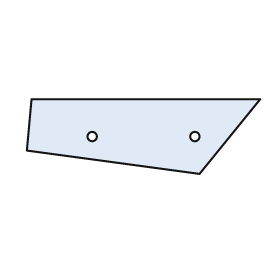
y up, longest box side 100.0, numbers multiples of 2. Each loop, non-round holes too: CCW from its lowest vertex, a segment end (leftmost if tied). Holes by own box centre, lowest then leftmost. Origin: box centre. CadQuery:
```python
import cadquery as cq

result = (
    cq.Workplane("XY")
    .moveTo(24.0, -16.0)
    .lineTo(50.0, 16.0)
    .lineTo(-48.0, 16.0)
    .lineTo(-50.0, -6.0)
    .close()
    .moveTo(-22.0, 0.0)
    .circle(2.0)
    .moveTo(22.0, 0.0)
    .circle(2.0)
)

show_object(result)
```